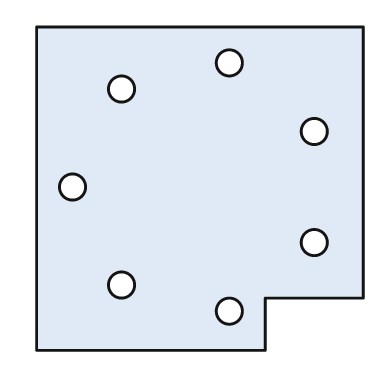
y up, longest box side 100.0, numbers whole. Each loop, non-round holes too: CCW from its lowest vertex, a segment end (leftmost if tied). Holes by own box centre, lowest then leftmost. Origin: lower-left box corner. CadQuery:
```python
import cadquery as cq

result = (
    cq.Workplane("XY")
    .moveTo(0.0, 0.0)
    .lineTo(70.0, 0.0)
    .lineTo(70.0, 16.0)
    .lineTo(100.0, 16.0)
    .lineTo(100.0, 99.0)
    .lineTo(0.0, 99.0)
    .close()
    .moveTo(59.0, 12.0)
    .circle(4.0)
    .moveTo(26.0, 20.0)
    .circle(4.0)
    .moveTo(85.0, 33.0)
    .circle(4.0)
    .moveTo(11.0, 50.0)
    .circle(4.0)
    .moveTo(85.0, 67.0)
    .circle(4.0)
    .moveTo(26.0, 80.0)
    .circle(4.0)
    .moveTo(59.0, 88.0)
    .circle(4.0)
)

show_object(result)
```